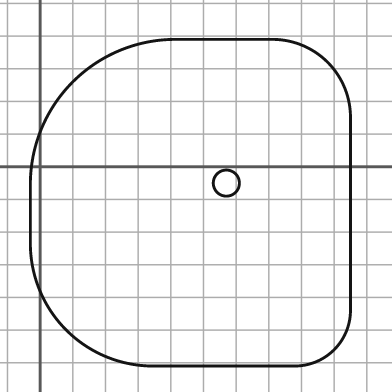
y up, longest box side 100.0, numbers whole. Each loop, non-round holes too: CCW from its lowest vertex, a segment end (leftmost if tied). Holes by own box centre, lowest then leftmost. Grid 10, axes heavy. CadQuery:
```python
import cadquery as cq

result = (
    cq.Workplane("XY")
    .moveTo(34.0, -61.0)
    .lineTo(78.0, -61.0)
    .threePointArc((90.0, -56.0), (95.0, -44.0))
    .lineTo(95.0, 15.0)
    .threePointArc((88.0, 32.0), (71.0, 39.0))
    .lineTo(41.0, 39.0)
    .threePointArc((10.0, 26.0), (-3.0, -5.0))
    .lineTo(-3.0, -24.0)
    .threePointArc((8.0, -50.0), (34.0, -61.0))
    .close()
    .moveTo(57.0, -5.0)
    .circle(4.0)
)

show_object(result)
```